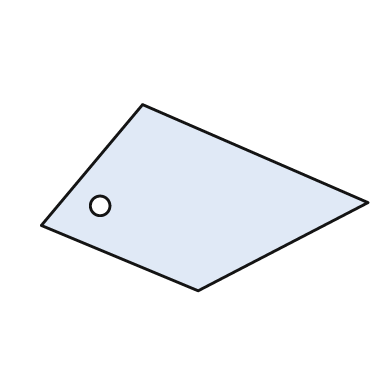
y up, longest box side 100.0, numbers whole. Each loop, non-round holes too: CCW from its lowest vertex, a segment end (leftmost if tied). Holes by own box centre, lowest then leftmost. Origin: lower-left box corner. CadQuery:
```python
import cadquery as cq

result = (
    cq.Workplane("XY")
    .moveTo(48.0, 0.0)
    .lineTo(100.0, 27.0)
    .lineTo(31.0, 57.0)
    .lineTo(0.0, 20.0)
    .close()
    .moveTo(18.0, 26.0)
    .circle(3.0)
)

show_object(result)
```